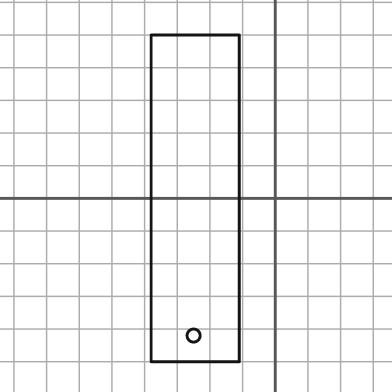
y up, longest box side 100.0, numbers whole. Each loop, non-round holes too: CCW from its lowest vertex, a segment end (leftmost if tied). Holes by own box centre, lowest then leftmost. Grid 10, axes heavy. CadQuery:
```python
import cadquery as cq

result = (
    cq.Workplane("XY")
    .moveTo(-38.0, -50.0)
    .lineTo(-11.0, -50.0)
    .lineTo(-11.0, 50.0)
    .lineTo(-38.0, 50.0)
    .close()
    .moveTo(-25.0, -42.0)
    .circle(2.0)
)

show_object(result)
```